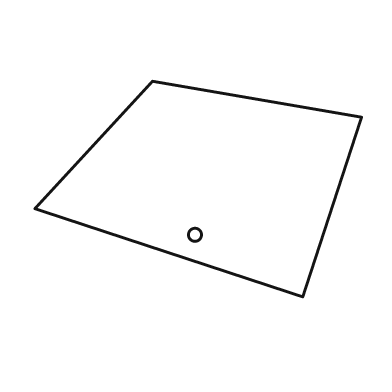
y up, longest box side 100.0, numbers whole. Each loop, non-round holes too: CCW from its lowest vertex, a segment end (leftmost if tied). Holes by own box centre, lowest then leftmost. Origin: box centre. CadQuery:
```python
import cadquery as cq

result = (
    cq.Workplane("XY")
    .moveTo(32.0, -33.0)
    .lineTo(50.0, 22.0)
    .lineTo(-14.0, 33.0)
    .lineTo(-50.0, -6.0)
    .close()
    .moveTo(-1.0, -14.0)
    .circle(2.0)
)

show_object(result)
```